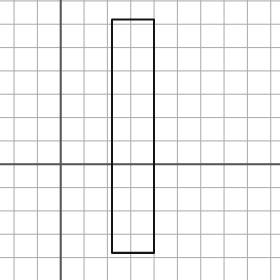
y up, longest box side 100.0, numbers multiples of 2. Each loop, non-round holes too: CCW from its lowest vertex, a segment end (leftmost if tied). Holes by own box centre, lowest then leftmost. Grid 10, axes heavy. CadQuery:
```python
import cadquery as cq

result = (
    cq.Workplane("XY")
    .moveTo(22.0, -38.0)
    .lineTo(40.0, -38.0)
    .lineTo(40.0, 62.0)
    .lineTo(22.0, 62.0)
    .close()
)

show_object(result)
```